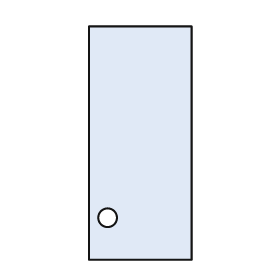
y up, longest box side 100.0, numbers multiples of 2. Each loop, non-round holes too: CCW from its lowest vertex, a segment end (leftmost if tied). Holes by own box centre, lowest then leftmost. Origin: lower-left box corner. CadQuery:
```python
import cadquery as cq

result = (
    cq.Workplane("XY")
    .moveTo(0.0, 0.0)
    .lineTo(44.0, 0.0)
    .lineTo(44.0, 100.0)
    .lineTo(0.0, 100.0)
    .close()
    .moveTo(8.0, 18.0)
    .circle(4.0)
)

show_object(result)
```